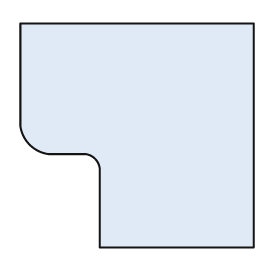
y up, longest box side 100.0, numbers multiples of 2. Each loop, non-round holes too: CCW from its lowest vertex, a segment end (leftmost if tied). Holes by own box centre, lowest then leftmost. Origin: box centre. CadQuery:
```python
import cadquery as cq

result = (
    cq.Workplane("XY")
    .moveTo(-16.0, -48.0)
    .lineTo(50.0, -48.0)
    .lineTo(50.0, 48.0)
    .lineTo(-50.0, 48.0)
    .lineTo(-50.0, 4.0)
    .threePointArc((-46.0, -4.0), (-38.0, -8.0))
    .lineTo(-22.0, -8.0)
    .threePointArc((-18.0, -10.0), (-16.0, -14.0))
    .close()
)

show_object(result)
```